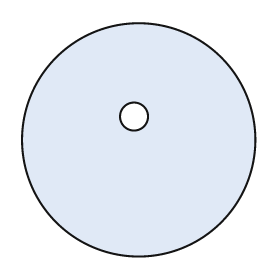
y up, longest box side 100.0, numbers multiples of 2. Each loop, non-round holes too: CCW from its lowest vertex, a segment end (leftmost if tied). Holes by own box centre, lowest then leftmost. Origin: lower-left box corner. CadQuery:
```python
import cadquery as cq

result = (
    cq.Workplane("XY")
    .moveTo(50.0, 50.0)
    .circle(50.0)
    .moveTo(48.0, 60.0)
    .circle(6.0)
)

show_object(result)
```